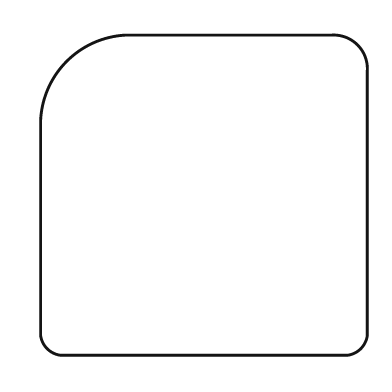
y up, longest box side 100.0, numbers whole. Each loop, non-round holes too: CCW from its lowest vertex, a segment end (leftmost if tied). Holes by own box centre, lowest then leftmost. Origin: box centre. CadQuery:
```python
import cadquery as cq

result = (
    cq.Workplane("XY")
    .moveTo(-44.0, -49.0)
    .lineTo(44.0, -49.0)
    .threePointArc((48.0, -47.0), (50.0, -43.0))
    .lineTo(50.0, 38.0)
    .threePointArc((47.0, 46.0), (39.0, 49.0))
    .lineTo(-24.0, 49.0)
    .threePointArc((-42.0, 41.0), (-50.0, 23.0))
    .lineTo(-50.0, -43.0)
    .threePointArc((-48.0, -47.0), (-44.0, -49.0))
    .close()
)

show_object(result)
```